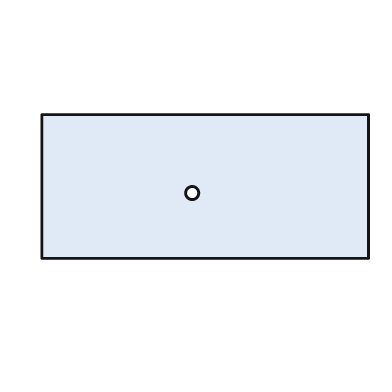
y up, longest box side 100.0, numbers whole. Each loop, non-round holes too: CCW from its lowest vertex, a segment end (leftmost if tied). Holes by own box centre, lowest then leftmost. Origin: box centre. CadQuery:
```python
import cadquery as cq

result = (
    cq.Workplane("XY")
    .moveTo(-50.0, -22.0)
    .lineTo(50.0, -22.0)
    .lineTo(50.0, 22.0)
    .lineTo(-50.0, 22.0)
    .close()
    .moveTo(-4.0, -2.0)
    .circle(2.0)
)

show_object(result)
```